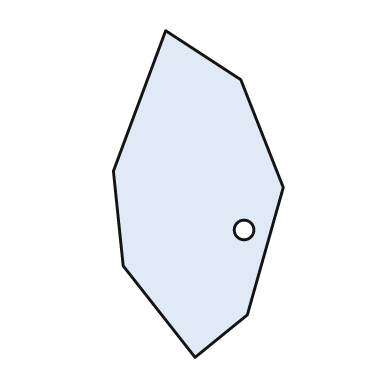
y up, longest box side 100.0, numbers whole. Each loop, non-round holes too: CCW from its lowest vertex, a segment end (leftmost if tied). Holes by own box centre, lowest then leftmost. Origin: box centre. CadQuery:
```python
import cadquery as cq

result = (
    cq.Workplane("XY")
    .moveTo(-1.0, -50.0)
    .lineTo(15.0, -37.0)
    .lineTo(26.0, 2.0)
    .lineTo(13.0, 35.0)
    .lineTo(-10.0, 50.0)
    .lineTo(-26.0, 7.0)
    .lineTo(-23.0, -22.0)
    .close()
    .moveTo(14.0, -11.0)
    .circle(3.0)
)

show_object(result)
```